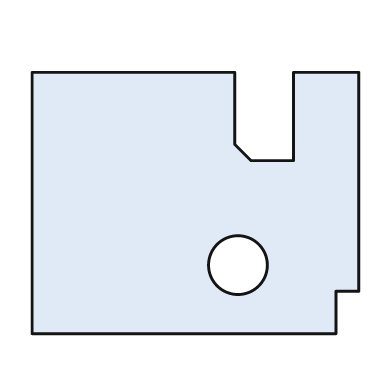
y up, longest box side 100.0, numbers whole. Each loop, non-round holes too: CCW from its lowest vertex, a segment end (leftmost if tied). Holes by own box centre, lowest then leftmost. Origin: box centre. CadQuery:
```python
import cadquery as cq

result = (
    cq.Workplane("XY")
    .moveTo(-50.0, -40.0)
    .lineTo(43.0, -40.0)
    .lineTo(43.0, -27.0)
    .lineTo(50.0, -27.0)
    .lineTo(50.0, 40.0)
    .lineTo(30.0, 40.0)
    .lineTo(30.0, 13.0)
    .lineTo(17.0, 13.0)
    .lineTo(12.0, 18.0)
    .lineTo(12.0, 40.0)
    .lineTo(-50.0, 40.0)
    .close()
    .moveTo(13.0, -19.0)
    .circle(9.0)
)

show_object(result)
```